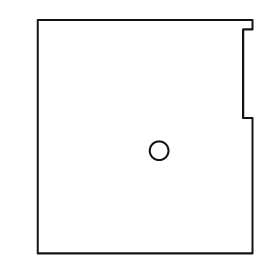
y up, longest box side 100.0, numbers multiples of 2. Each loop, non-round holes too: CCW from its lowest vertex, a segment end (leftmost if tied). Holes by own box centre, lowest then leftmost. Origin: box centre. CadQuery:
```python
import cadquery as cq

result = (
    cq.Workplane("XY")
    .moveTo(-46.0, -50.0)
    .lineTo(46.0, -50.0)
    .lineTo(46.0, 8.0)
    .lineTo(42.0, 8.0)
    .lineTo(42.0, 46.0)
    .lineTo(46.0, 46.0)
    .lineTo(46.0, 50.0)
    .lineTo(-46.0, 50.0)
    .close()
    .moveTo(6.0, -6.0)
    .circle(4.0)
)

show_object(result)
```